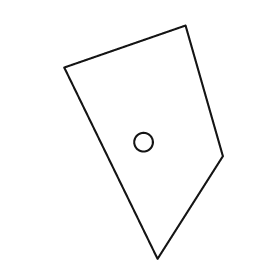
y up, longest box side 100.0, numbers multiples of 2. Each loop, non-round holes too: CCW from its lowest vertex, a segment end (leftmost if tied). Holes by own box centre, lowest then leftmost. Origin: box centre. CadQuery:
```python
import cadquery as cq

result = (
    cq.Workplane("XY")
    .moveTo(6.0, -50.0)
    .lineTo(34.0, -6.0)
    .lineTo(18.0, 50.0)
    .lineTo(-34.0, 32.0)
    .close()
    .moveTo(0.0, 0.0)
    .circle(4.0)
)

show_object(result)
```